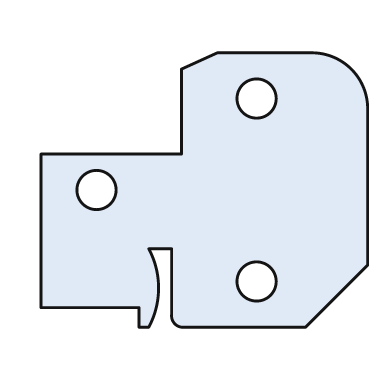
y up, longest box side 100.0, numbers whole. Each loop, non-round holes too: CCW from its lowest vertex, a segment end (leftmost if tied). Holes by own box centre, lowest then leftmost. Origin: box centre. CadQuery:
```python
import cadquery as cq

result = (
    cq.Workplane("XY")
    .moveTo(-20.0, -42.0)
    .lineTo(-17.0, -42.0)
    .threePointArc((-14.0, -30.0), (-17.0, -18.0))
    .lineTo(-10.0, -18.0)
    .lineTo(-10.0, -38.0)
    .threePointArc((-9.0, -41.0), (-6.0, -42.0))
    .lineTo(31.0, -42.0)
    .lineTo(50.0, -23.0)
    .lineTo(50.0, 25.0)
    .threePointArc((45.0, 37.0), (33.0, 42.0))
    .lineTo(4.0, 42.0)
    .lineTo(-7.0, 37.0)
    .lineTo(-7.0, 11.0)
    .lineTo(-50.0, 11.0)
    .lineTo(-50.0, -36.0)
    .lineTo(-20.0, -36.0)
    .close()
    .moveTo(16.0, -28.0)
    .circle(6.0)
    .moveTo(-33.0, 0.0)
    .circle(6.0)
    .moveTo(16.0, 28.0)
    .circle(6.0)
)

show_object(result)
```